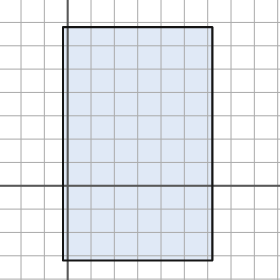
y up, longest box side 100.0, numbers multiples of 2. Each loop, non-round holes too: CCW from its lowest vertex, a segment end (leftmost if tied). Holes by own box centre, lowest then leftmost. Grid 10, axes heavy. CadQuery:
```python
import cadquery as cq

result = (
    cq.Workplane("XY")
    .moveTo(-2.0, -32.0)
    .lineTo(62.0, -32.0)
    .lineTo(62.0, 68.0)
    .lineTo(-2.0, 68.0)
    .close()
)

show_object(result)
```